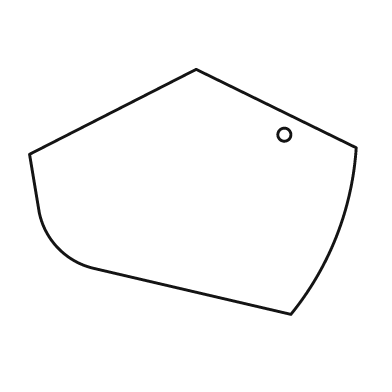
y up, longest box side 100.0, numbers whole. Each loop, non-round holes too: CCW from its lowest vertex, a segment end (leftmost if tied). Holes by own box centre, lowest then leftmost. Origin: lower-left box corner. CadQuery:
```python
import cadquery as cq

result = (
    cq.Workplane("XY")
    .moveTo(80.0, 0.0)
    .threePointArc((94.0, 24.0), (100.0, 51.0))
    .lineTo(51.0, 75.0)
    .lineTo(0.0, 49.0)
    .lineTo(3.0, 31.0)
    .threePointArc((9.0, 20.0), (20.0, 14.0))
    .close()
    .moveTo(78.0, 55.0)
    .circle(2.0)
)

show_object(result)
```